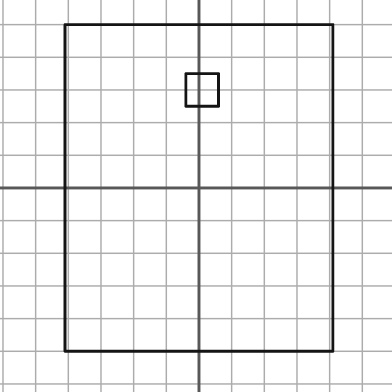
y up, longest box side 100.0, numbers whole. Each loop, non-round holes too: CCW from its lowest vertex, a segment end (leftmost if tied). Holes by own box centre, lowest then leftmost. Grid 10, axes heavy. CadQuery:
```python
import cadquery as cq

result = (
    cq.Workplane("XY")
    .moveTo(-41.0, -50.0)
    .lineTo(41.0, -50.0)
    .lineTo(41.0, 50.0)
    .lineTo(-41.0, 50.0)
    .close()
    .moveTo(-4.0, 25.0)
    .lineTo(6.0, 25.0)
    .lineTo(6.0, 35.0)
    .lineTo(-4.0, 35.0)
    .close()
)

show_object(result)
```